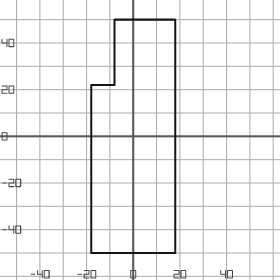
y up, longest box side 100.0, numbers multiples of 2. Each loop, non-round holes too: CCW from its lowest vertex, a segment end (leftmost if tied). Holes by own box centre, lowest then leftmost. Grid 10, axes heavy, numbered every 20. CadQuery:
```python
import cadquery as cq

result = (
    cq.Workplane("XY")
    .moveTo(-18.0, -50.0)
    .lineTo(18.0, -50.0)
    .lineTo(18.0, 50.0)
    .lineTo(-8.0, 50.0)
    .lineTo(-8.0, 22.0)
    .lineTo(-18.0, 22.0)
    .close()
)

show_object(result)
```